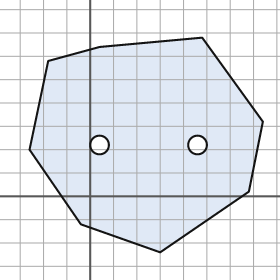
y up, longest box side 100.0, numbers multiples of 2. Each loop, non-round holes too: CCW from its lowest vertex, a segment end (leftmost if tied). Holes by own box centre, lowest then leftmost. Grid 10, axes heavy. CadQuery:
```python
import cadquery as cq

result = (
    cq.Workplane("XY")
    .moveTo(30.0, -24.0)
    .lineTo(68.0, 2.0)
    .lineTo(74.0, 32.0)
    .lineTo(48.0, 68.0)
    .lineTo(4.0, 64.0)
    .lineTo(-18.0, 58.0)
    .lineTo(-26.0, 20.0)
    .lineTo(-4.0, -12.0)
    .close()
    .moveTo(4.0, 22.0)
    .circle(4.0)
    .moveTo(46.0, 22.0)
    .circle(4.0)
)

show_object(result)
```